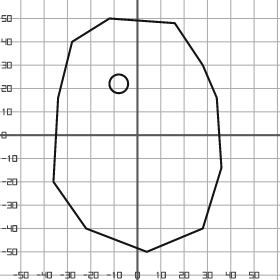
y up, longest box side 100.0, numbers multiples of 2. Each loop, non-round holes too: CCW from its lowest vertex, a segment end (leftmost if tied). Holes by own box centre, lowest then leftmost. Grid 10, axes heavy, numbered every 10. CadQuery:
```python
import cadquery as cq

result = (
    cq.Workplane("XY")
    .moveTo(4.0, -50.0)
    .lineTo(28.0, -40.0)
    .lineTo(36.0, -14.0)
    .lineTo(34.0, 16.0)
    .lineTo(28.0, 30.0)
    .lineTo(16.0, 48.0)
    .lineTo(-12.0, 50.0)
    .lineTo(-28.0, 40.0)
    .lineTo(-34.0, 16.0)
    .lineTo(-36.0, -20.0)
    .lineTo(-22.0, -40.0)
    .close()
    .moveTo(-8.0, 22.0)
    .circle(4.0)
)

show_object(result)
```